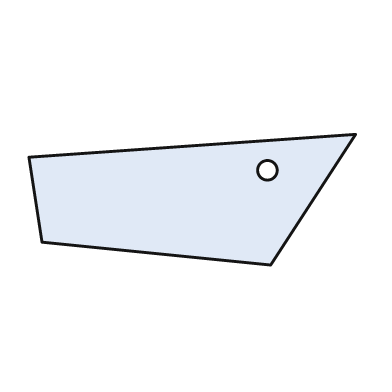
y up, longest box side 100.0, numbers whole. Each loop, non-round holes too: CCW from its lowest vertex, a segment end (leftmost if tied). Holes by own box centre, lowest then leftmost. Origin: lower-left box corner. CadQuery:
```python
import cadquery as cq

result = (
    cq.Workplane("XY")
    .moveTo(74.0, 0.0)
    .lineTo(100.0, 40.0)
    .lineTo(0.0, 33.0)
    .lineTo(4.0, 7.0)
    .close()
    .moveTo(73.0, 29.0)
    .circle(3.0)
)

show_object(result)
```